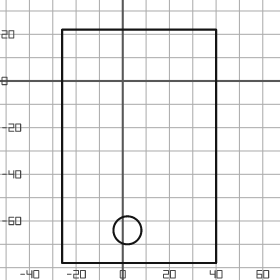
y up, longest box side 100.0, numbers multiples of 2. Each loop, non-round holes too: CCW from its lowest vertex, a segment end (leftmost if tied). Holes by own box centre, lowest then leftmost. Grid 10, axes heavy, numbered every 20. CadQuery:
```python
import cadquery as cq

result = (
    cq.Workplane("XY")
    .moveTo(-26.0, -78.0)
    .lineTo(40.0, -78.0)
    .lineTo(40.0, 22.0)
    .lineTo(-26.0, 22.0)
    .close()
    .moveTo(2.0, -64.0)
    .circle(6.0)
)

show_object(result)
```